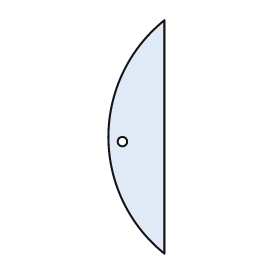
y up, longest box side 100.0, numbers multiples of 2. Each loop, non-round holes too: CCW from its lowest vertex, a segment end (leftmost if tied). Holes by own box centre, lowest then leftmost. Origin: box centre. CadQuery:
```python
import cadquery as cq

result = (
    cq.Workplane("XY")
    .moveTo(12.0, -50.0)
    .lineTo(12.0, 50.0)
    .threePointArc((-12.0, 0.0), (12.0, -50.0))
    .close()
    .moveTo(-6.0, -2.0)
    .circle(2.0)
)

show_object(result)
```